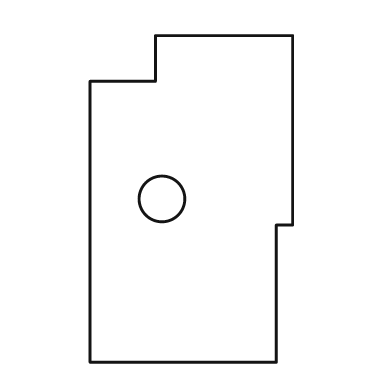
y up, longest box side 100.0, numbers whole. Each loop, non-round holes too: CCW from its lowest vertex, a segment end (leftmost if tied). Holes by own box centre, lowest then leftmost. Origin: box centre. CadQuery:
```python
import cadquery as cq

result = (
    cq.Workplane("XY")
    .moveTo(-31.0, -50.0)
    .lineTo(26.0, -50.0)
    .lineTo(26.0, -8.0)
    .lineTo(31.0, -8.0)
    .lineTo(31.0, 50.0)
    .lineTo(-11.0, 50.0)
    .lineTo(-11.0, 36.0)
    .lineTo(-31.0, 36.0)
    .close()
    .moveTo(-9.0, 0.0)
    .circle(7.0)
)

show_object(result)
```